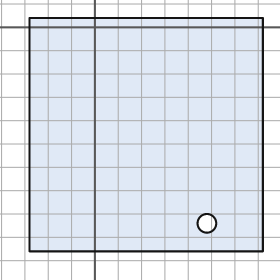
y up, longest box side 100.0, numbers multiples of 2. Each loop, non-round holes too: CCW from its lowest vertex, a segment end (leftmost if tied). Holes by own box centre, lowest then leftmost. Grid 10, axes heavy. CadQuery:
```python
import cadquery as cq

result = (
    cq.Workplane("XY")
    .moveTo(-28.0, -96.0)
    .lineTo(72.0, -96.0)
    .lineTo(72.0, 4.0)
    .lineTo(-28.0, 4.0)
    .close()
    .moveTo(48.0, -84.0)
    .circle(4.0)
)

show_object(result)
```